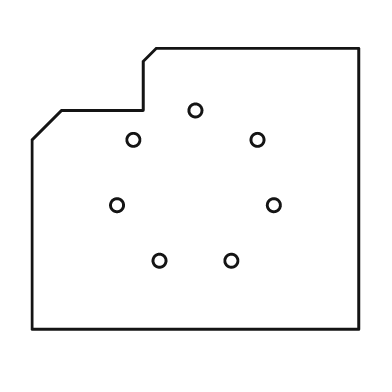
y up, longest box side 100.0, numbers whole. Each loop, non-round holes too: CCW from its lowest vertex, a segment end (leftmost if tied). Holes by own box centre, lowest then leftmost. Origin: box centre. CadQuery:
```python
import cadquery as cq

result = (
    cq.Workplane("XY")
    .moveTo(-50.0, -43.0)
    .lineTo(50.0, -43.0)
    .lineTo(50.0, 43.0)
    .lineTo(-12.0, 43.0)
    .lineTo(-16.0, 39.0)
    .lineTo(-16.0, 24.0)
    .lineTo(-41.0, 24.0)
    .lineTo(-50.0, 15.0)
    .close()
    .moveTo(-11.0, -22.0)
    .circle(2.0)
    .moveTo(11.0, -22.0)
    .circle(2.0)
    .moveTo(-24.0, -5.0)
    .circle(2.0)
    .moveTo(24.0, -5.0)
    .circle(2.0)
    .moveTo(-19.0, 15.0)
    .circle(2.0)
    .moveTo(19.0, 15.0)
    .circle(2.0)
    .moveTo(0.0, 24.0)
    .circle(2.0)
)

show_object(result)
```